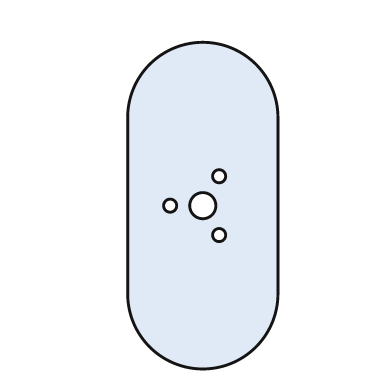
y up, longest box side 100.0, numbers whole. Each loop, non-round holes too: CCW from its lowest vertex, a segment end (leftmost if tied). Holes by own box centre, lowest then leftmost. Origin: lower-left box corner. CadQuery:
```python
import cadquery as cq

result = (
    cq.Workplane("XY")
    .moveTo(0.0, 23.0)
    .threePointArc((23.0, 0.0), (46.0, 23.0))
    .lineTo(46.0, 77.0)
    .threePointArc((23.0, 100.0), (0.0, 77.0))
    .close()
    .moveTo(28.0, 41.0)
    .circle(2.0)
    .moveTo(13.0, 50.0)
    .circle(2.0)
    .moveTo(23.0, 50.0)
    .circle(4.0)
    .moveTo(28.0, 59.0)
    .circle(2.0)
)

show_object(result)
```